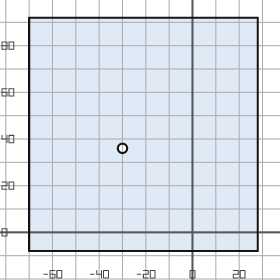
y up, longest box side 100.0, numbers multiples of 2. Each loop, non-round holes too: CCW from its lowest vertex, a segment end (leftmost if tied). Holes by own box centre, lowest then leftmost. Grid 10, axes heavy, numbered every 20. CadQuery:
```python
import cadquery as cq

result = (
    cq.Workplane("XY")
    .moveTo(-70.0, -8.0)
    .lineTo(28.0, -8.0)
    .lineTo(28.0, 92.0)
    .lineTo(-70.0, 92.0)
    .close()
    .moveTo(-30.0, 36.0)
    .circle(2.0)
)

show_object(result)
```